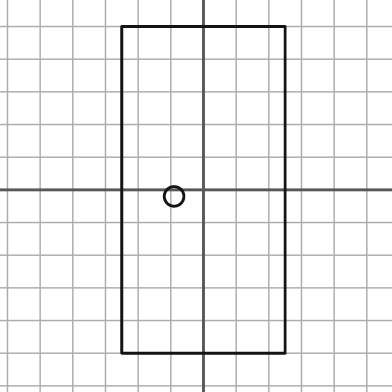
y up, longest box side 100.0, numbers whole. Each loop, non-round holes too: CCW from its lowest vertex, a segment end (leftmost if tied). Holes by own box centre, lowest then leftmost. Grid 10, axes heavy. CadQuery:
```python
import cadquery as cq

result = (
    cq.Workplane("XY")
    .moveTo(-25.0, -50.0)
    .lineTo(25.0, -50.0)
    .lineTo(25.0, 50.0)
    .lineTo(-25.0, 50.0)
    .close()
    .moveTo(-9.0, -2.0)
    .circle(3.0)
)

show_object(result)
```